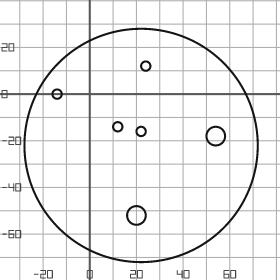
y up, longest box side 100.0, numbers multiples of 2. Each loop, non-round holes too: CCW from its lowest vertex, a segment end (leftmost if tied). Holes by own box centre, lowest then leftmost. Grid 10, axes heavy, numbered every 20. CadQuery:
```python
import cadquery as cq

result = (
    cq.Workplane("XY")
    .moveTo(22.0, -22.0)
    .circle(50.0)
    .moveTo(20.0, -52.0)
    .circle(4.0)
    .moveTo(54.0, -18.0)
    .circle(4.0)
    .moveTo(22.0, -16.0)
    .circle(2.0)
    .moveTo(12.0, -14.0)
    .circle(2.0)
    .moveTo(-14.0, 0.0)
    .circle(2.0)
    .moveTo(24.0, 12.0)
    .circle(2.0)
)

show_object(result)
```